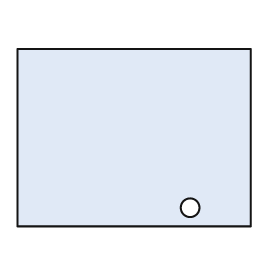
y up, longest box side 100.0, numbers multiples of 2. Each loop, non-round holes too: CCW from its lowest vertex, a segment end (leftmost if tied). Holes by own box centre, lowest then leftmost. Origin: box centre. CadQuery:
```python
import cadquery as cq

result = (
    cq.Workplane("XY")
    .moveTo(-50.0, -38.0)
    .lineTo(50.0, -38.0)
    .lineTo(50.0, 38.0)
    .lineTo(-50.0, 38.0)
    .close()
    .moveTo(24.0, -30.0)
    .circle(4.0)
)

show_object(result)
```